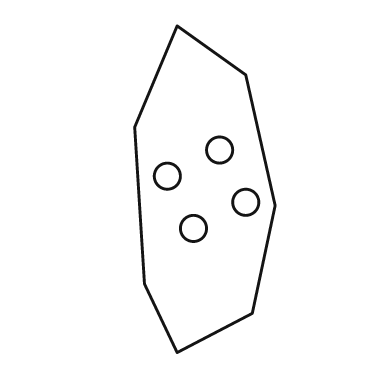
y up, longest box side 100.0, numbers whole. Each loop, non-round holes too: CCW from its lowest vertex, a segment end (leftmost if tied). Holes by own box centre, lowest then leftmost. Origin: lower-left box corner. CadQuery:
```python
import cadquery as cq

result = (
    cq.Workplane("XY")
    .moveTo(13.0, 0.0)
    .lineTo(36.0, 12.0)
    .lineTo(43.0, 45.0)
    .lineTo(34.0, 85.0)
    .lineTo(13.0, 100.0)
    .lineTo(0.0, 69.0)
    .lineTo(3.0, 21.0)
    .close()
    .moveTo(18.0, 38.0)
    .circle(4.0)
    .moveTo(34.0, 46.0)
    .circle(4.0)
    .moveTo(10.0, 54.0)
    .circle(4.0)
    .moveTo(26.0, 62.0)
    .circle(4.0)
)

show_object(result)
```